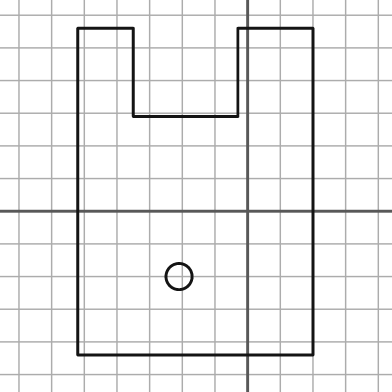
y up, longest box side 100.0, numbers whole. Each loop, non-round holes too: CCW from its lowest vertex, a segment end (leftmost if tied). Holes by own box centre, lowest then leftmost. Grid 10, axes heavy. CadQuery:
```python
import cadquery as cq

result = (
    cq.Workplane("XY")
    .moveTo(-52.0, -44.0)
    .lineTo(20.0, -44.0)
    .lineTo(20.0, 56.0)
    .lineTo(-3.0, 56.0)
    .lineTo(-3.0, 29.0)
    .lineTo(-35.0, 29.0)
    .lineTo(-35.0, 56.0)
    .lineTo(-52.0, 56.0)
    .close()
    .moveTo(-21.0, -20.0)
    .circle(4.0)
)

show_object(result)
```